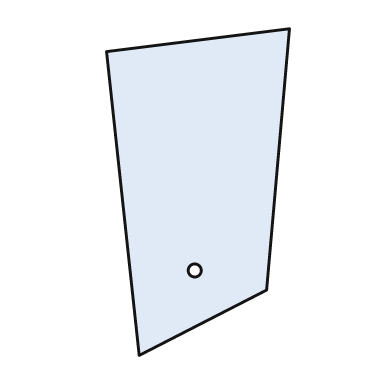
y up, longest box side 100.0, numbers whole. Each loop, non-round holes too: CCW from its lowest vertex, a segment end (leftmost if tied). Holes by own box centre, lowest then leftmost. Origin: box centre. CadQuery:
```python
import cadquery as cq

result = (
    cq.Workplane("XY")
    .moveTo(-18.0, -50.0)
    .lineTo(21.0, -30.0)
    .lineTo(28.0, 50.0)
    .lineTo(-28.0, 43.0)
    .close()
    .moveTo(-1.0, -24.0)
    .circle(2.0)
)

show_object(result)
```